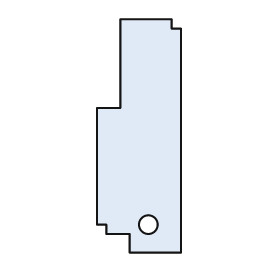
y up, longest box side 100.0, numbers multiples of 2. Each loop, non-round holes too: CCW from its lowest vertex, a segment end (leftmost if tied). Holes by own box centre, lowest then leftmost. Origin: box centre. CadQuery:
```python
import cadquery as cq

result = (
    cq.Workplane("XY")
    .moveTo(-4.0, -50.0)
    .lineTo(18.0, -50.0)
    .lineTo(18.0, 46.0)
    .lineTo(14.0, 46.0)
    .lineTo(14.0, 50.0)
    .lineTo(-8.0, 50.0)
    .lineTo(-8.0, 12.0)
    .lineTo(-18.0, 12.0)
    .lineTo(-18.0, -38.0)
    .lineTo(-14.0, -38.0)
    .lineTo(-14.0, -42.0)
    .lineTo(-4.0, -42.0)
    .close()
    .moveTo(4.0, -38.0)
    .circle(4.0)
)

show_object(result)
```